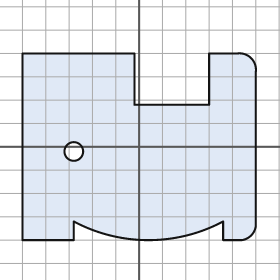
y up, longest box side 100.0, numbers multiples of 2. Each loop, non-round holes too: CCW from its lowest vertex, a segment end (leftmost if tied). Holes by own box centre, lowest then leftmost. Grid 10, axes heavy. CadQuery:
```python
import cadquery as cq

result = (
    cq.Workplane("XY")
    .moveTo(-50.0, -40.0)
    .lineTo(-28.0, -40.0)
    .lineTo(-28.0, -32.0)
    .threePointArc((4.0, -40.0), (36.0, -32.0))
    .lineTo(36.0, -40.0)
    .lineTo(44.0, -40.0)
    .threePointArc((48.0, -38.0), (50.0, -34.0))
    .lineTo(50.0, 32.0)
    .threePointArc((48.0, 38.0), (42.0, 40.0))
    .lineTo(30.0, 40.0)
    .lineTo(30.0, 18.0)
    .lineTo(-2.0, 18.0)
    .lineTo(-2.0, 40.0)
    .lineTo(-50.0, 40.0)
    .close()
    .moveTo(-28.0, -2.0)
    .circle(4.0)
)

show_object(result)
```